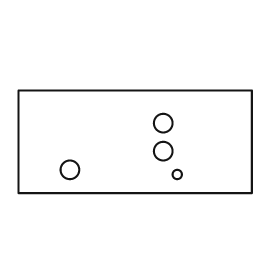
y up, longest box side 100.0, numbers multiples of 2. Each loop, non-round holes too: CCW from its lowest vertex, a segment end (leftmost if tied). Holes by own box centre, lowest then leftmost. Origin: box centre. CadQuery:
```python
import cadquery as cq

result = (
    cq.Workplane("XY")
    .moveTo(-50.0, -22.0)
    .lineTo(50.0, -22.0)
    .lineTo(50.0, 22.0)
    .lineTo(-50.0, 22.0)
    .close()
    .moveTo(18.0, -14.0)
    .circle(2.0)
    .moveTo(-28.0, -12.0)
    .circle(4.0)
    .moveTo(12.0, -4.0)
    .circle(4.0)
    .moveTo(12.0, 8.0)
    .circle(4.0)
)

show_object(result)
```